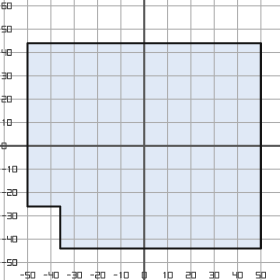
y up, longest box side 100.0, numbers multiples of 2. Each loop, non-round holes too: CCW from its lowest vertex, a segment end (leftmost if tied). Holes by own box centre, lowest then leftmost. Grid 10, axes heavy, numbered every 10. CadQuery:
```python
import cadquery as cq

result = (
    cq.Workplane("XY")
    .moveTo(-36.0, -44.0)
    .lineTo(50.0, -44.0)
    .lineTo(50.0, 44.0)
    .lineTo(-50.0, 44.0)
    .lineTo(-50.0, -26.0)
    .lineTo(-36.0, -26.0)
    .close()
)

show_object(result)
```